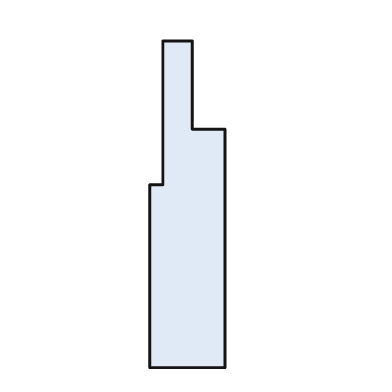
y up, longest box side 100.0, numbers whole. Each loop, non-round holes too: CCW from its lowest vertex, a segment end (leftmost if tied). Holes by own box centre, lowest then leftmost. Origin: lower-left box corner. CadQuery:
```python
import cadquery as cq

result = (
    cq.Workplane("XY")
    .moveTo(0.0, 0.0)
    .lineTo(23.0, 0.0)
    .lineTo(23.0, 73.0)
    .lineTo(13.0, 73.0)
    .lineTo(13.0, 100.0)
    .lineTo(4.0, 100.0)
    .lineTo(4.0, 56.0)
    .lineTo(0.0, 56.0)
    .close()
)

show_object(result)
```